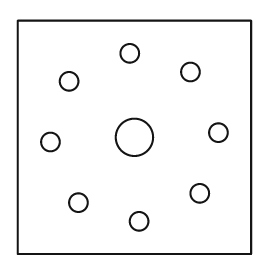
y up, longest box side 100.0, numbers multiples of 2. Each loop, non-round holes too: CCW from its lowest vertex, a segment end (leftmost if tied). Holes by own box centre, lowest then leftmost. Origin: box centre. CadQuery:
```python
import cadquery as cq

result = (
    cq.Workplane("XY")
    .moveTo(-50.0, -50.0)
    .lineTo(50.0, -50.0)
    .lineTo(50.0, 50.0)
    .lineTo(-50.0, 50.0)
    .close()
    .moveTo(2.0, -36.0)
    .circle(4.0)
    .moveTo(-24.0, -28.0)
    .circle(4.0)
    .moveTo(28.0, -24.0)
    .circle(4.0)
    .moveTo(-36.0, -2.0)
    .circle(4.0)
    .moveTo(0.0, 0.0)
    .circle(8.0)
    .moveTo(36.0, 2.0)
    .circle(4.0)
    .moveTo(-28.0, 24.0)
    .circle(4.0)
    .moveTo(24.0, 28.0)
    .circle(4.0)
    .moveTo(-2.0, 36.0)
    .circle(4.0)
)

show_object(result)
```